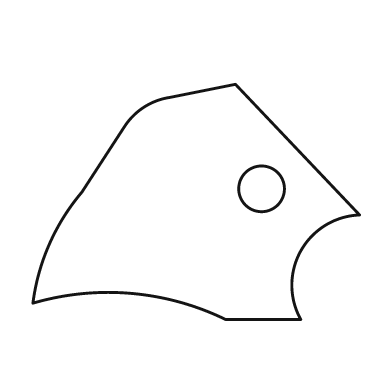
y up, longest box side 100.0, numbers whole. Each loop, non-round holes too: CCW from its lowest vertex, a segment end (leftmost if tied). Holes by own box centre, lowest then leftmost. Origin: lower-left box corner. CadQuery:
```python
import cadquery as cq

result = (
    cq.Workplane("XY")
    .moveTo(59.0, 0.0)
    .lineTo(82.0, 0.0)
    .threePointArc((82.0, 21.0), (100.0, 32.0))
    .lineTo(62.0, 72.0)
    .lineTo(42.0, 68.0)
    .threePointArc((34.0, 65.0), (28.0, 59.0))
    .lineTo(15.0, 39.0)
    .threePointArc((5.0, 23.0), (0.0, 5.0))
    .threePointArc((30.0, 8.0), (59.0, 0.0))
    .close()
    .moveTo(70.0, 40.0)
    .circle(7.0)
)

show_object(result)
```